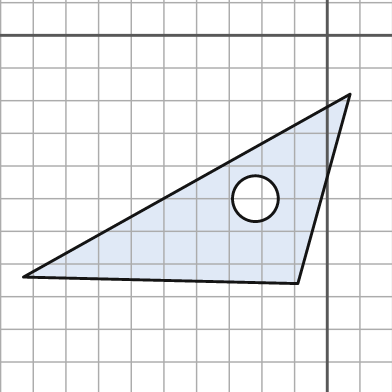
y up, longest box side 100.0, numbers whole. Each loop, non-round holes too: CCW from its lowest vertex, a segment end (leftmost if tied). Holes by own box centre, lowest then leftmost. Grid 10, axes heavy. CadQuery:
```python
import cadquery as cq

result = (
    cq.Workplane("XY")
    .moveTo(-9.0, -76.0)
    .lineTo(7.0, -18.0)
    .lineTo(-93.0, -74.0)
    .close()
    .moveTo(-22.0, -50.0)
    .circle(7.0)
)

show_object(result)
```